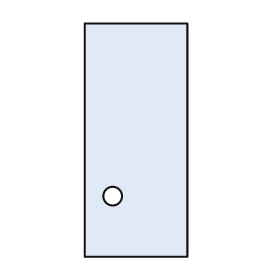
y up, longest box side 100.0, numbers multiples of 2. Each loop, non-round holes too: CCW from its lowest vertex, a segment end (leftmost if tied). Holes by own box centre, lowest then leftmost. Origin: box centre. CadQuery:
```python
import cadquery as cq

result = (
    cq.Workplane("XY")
    .moveTo(-22.0, -50.0)
    .lineTo(22.0, -50.0)
    .lineTo(22.0, 50.0)
    .lineTo(-22.0, 50.0)
    .close()
    .moveTo(-10.0, -24.0)
    .circle(4.0)
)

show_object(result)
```